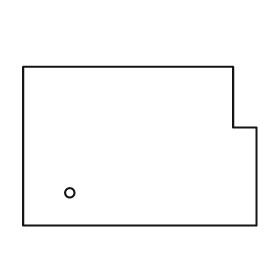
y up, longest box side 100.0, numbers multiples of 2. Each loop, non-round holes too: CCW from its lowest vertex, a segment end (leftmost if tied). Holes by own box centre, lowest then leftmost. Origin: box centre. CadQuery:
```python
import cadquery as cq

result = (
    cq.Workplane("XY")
    .moveTo(-50.0, -34.0)
    .lineTo(50.0, -34.0)
    .lineTo(50.0, 8.0)
    .lineTo(40.0, 8.0)
    .lineTo(40.0, 34.0)
    .lineTo(-50.0, 34.0)
    .close()
    .moveTo(-30.0, -20.0)
    .circle(2.0)
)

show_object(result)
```